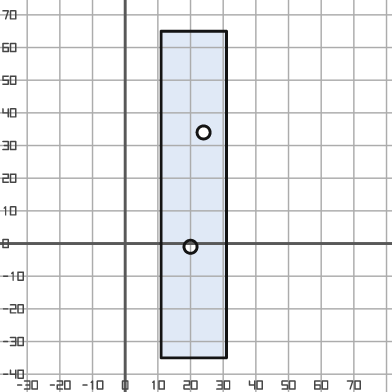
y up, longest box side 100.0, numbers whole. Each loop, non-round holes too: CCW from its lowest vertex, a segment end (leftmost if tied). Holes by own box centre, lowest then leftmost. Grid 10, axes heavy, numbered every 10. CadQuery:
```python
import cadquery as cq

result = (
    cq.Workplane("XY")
    .moveTo(11.0, -35.0)
    .lineTo(31.0, -35.0)
    .lineTo(31.0, 65.0)
    .lineTo(11.0, 65.0)
    .close()
    .moveTo(20.0, -1.0)
    .circle(2.0)
    .moveTo(24.0, 34.0)
    .circle(2.0)
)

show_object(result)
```